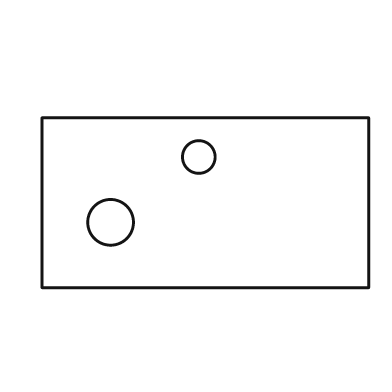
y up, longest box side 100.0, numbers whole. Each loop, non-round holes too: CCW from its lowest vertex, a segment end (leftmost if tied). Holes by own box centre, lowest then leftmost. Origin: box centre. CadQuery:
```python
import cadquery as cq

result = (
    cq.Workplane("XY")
    .moveTo(-50.0, -26.0)
    .lineTo(50.0, -26.0)
    .lineTo(50.0, 26.0)
    .lineTo(-50.0, 26.0)
    .close()
    .moveTo(-29.0, -6.0)
    .circle(7.0)
    .moveTo(-2.0, 14.0)
    .circle(5.0)
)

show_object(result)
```